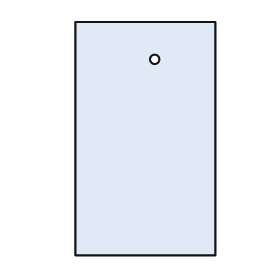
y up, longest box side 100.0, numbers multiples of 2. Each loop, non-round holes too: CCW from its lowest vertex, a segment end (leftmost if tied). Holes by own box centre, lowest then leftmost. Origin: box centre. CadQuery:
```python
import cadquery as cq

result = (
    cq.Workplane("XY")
    .moveTo(-30.0, -50.0)
    .lineTo(30.0, -50.0)
    .lineTo(30.0, 50.0)
    .lineTo(-30.0, 50.0)
    .close()
    .moveTo(4.0, 34.0)
    .circle(2.0)
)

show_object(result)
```